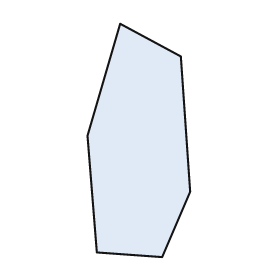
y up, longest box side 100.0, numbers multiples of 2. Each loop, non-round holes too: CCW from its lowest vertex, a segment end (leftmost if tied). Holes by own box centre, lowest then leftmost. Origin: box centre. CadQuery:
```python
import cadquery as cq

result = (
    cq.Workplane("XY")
    .moveTo(10.0, -50.0)
    .lineTo(22.0, -22.0)
    .lineTo(18.0, 36.0)
    .lineTo(-8.0, 50.0)
    .lineTo(-22.0, 2.0)
    .lineTo(-18.0, -48.0)
    .close()
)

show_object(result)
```